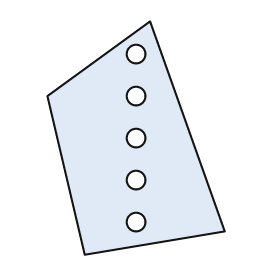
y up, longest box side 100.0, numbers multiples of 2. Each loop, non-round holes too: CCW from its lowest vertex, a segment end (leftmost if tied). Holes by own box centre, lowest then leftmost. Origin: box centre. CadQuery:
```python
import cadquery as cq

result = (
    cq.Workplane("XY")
    .moveTo(-22.0, -50.0)
    .lineTo(38.0, -40.0)
    .lineTo(6.0, 50.0)
    .lineTo(-38.0, 18.0)
    .close()
    .moveTo(0.0, -36.0)
    .circle(4.0)
    .moveTo(0.0, -18.0)
    .circle(4.0)
    .moveTo(0.0, 0.0)
    .circle(4.0)
    .moveTo(0.0, 18.0)
    .circle(4.0)
    .moveTo(0.0, 36.0)
    .circle(4.0)
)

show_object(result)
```